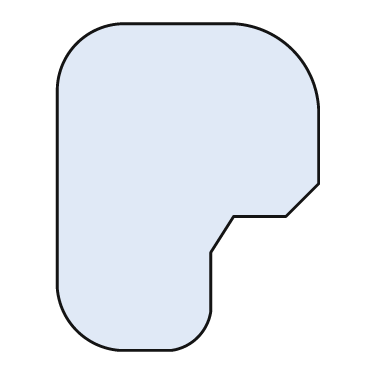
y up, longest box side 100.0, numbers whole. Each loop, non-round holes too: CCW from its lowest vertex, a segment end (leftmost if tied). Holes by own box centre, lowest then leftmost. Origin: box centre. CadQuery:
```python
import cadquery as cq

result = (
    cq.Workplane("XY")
    .moveTo(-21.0, -50.0)
    .lineTo(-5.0, -50.0)
    .threePointArc((3.0, -46.0), (7.0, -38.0))
    .lineTo(7.0, -20.0)
    .lineTo(14.0, -9.0)
    .lineTo(30.0, -9.0)
    .lineTo(40.0, 1.0)
    .lineTo(40.0, 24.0)
    .threePointArc((32.0, 42.0), (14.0, 50.0))
    .lineTo(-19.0, 50.0)
    .threePointArc((-34.0, 44.0), (-40.0, 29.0))
    .lineTo(-40.0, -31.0)
    .threePointArc((-34.0, -44.0), (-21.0, -50.0))
    .close()
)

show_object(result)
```